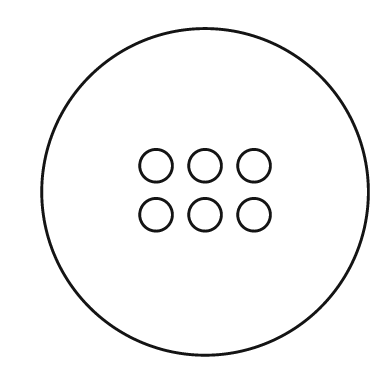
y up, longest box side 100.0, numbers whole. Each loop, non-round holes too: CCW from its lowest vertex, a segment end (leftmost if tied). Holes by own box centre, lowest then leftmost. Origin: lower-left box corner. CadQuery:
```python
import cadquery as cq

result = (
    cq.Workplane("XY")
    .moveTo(50.0, 50.0)
    .circle(50.0)
    .moveTo(35.0, 43.0)
    .circle(5.0)
    .moveTo(50.0, 43.0)
    .circle(5.0)
    .moveTo(65.0, 43.0)
    .circle(5.0)
    .moveTo(35.0, 58.0)
    .circle(5.0)
    .moveTo(50.0, 58.0)
    .circle(5.0)
    .moveTo(65.0, 58.0)
    .circle(5.0)
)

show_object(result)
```